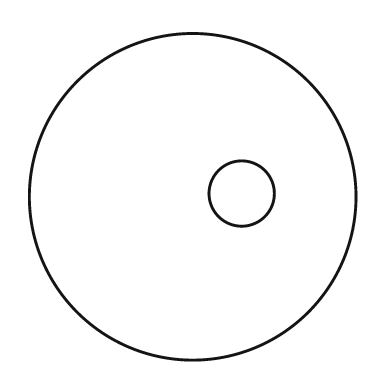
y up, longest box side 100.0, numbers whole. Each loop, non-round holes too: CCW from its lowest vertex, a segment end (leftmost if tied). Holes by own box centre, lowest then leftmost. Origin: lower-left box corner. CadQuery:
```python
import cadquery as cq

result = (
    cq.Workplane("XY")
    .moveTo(50.0, 50.0)
    .circle(50.0)
    .moveTo(65.0, 51.0)
    .circle(10.0)
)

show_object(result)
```